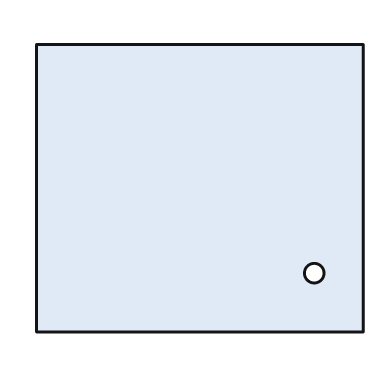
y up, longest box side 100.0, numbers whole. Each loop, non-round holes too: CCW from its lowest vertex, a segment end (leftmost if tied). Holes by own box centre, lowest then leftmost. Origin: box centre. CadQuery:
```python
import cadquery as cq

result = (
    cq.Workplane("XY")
    .moveTo(-50.0, -44.0)
    .lineTo(50.0, -44.0)
    .lineTo(50.0, 44.0)
    .lineTo(-50.0, 44.0)
    .close()
    .moveTo(35.0, -26.0)
    .circle(3.0)
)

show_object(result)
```